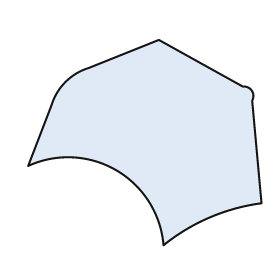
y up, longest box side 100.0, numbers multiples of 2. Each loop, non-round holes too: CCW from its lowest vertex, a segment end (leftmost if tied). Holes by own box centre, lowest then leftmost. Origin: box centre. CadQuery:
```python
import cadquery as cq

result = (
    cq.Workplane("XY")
    .moveTo(8.0, -44.0)
    .threePointArc((28.0, -32.0), (50.0, -26.0))
    .lineTo(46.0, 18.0)
    .threePointArc((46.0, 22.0), (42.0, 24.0))
    .lineTo(6.0, 44.0)
    .lineTo(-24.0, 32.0)
    .threePointArc((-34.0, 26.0), (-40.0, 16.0))
    .lineTo(-50.0, -10.0)
    .threePointArc((-12.0, -12.0), (8.0, -44.0))
    .close()
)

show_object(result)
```